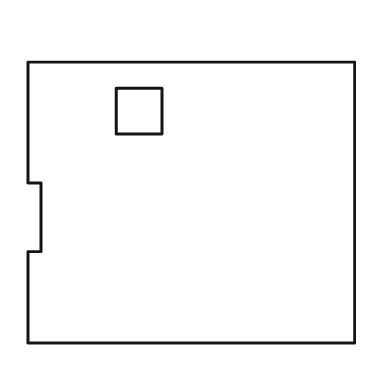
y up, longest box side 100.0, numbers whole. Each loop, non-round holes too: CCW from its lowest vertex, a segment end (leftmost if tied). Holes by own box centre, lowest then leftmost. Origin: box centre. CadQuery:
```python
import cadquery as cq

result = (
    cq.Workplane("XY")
    .moveTo(-50.0, -43.0)
    .lineTo(50.0, -43.0)
    .lineTo(50.0, 43.0)
    .lineTo(-50.0, 43.0)
    .lineTo(-50.0, 6.0)
    .lineTo(-46.0, 6.0)
    .lineTo(-46.0, -15.0)
    .lineTo(-50.0, -15.0)
    .close()
    .moveTo(-23.0, 21.0)
    .lineTo(-9.0, 21.0)
    .lineTo(-9.0, 35.0)
    .lineTo(-23.0, 35.0)
    .close()
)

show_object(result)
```